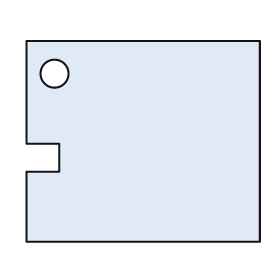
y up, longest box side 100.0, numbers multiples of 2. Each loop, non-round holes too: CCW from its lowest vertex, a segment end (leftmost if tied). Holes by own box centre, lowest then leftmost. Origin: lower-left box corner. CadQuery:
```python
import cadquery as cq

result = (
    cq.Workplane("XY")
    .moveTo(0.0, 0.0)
    .lineTo(100.0, 0.0)
    .lineTo(100.0, 86.0)
    .lineTo(0.0, 86.0)
    .lineTo(0.0, 42.0)
    .lineTo(14.0, 42.0)
    .lineTo(14.0, 30.0)
    .lineTo(0.0, 30.0)
    .close()
    .moveTo(12.0, 72.0)
    .circle(6.0)
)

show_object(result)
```